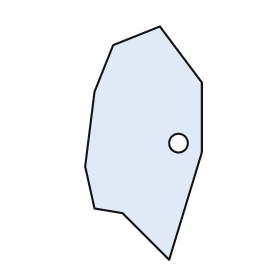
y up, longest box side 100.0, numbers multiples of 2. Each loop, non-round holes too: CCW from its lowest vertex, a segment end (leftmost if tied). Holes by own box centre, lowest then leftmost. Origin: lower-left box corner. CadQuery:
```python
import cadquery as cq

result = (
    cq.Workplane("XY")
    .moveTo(36.0, 0.0)
    .lineTo(50.0, 46.0)
    .lineTo(50.0, 76.0)
    .lineTo(32.0, 100.0)
    .lineTo(12.0, 92.0)
    .lineTo(4.0, 72.0)
    .lineTo(0.0, 40.0)
    .lineTo(4.0, 22.0)
    .lineTo(16.0, 20.0)
    .close()
    .moveTo(40.0, 50.0)
    .circle(4.0)
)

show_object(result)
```